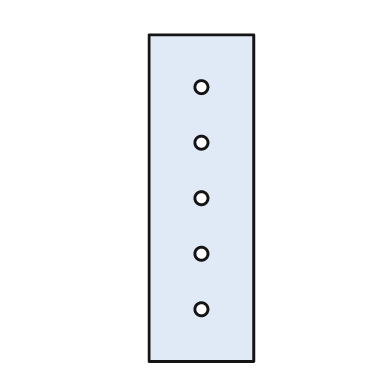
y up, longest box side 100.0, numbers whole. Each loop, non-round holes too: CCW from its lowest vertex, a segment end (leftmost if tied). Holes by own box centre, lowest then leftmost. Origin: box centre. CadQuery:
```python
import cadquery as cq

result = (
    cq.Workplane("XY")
    .moveTo(-16.0, -50.0)
    .lineTo(16.0, -50.0)
    .lineTo(16.0, 50.0)
    .lineTo(-16.0, 50.0)
    .close()
    .moveTo(0.0, -34.0)
    .circle(2.0)
    .moveTo(0.0, -17.0)
    .circle(2.0)
    .moveTo(0.0, 0.0)
    .circle(2.0)
    .moveTo(0.0, 17.0)
    .circle(2.0)
    .moveTo(0.0, 34.0)
    .circle(2.0)
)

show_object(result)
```